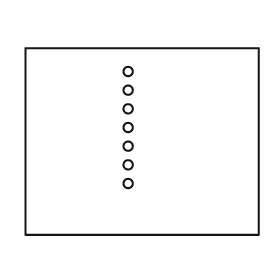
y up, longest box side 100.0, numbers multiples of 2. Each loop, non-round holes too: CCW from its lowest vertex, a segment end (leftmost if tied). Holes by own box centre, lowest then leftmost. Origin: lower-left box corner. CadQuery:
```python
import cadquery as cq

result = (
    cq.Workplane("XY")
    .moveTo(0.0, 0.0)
    .lineTo(100.0, 0.0)
    .lineTo(100.0, 80.0)
    .lineTo(0.0, 80.0)
    .close()
    .moveTo(44.0, 22.0)
    .circle(2.0)
    .moveTo(44.0, 30.0)
    .circle(2.0)
    .moveTo(44.0, 38.0)
    .circle(2.0)
    .moveTo(44.0, 46.0)
    .circle(2.0)
    .moveTo(44.0, 54.0)
    .circle(2.0)
    .moveTo(44.0, 62.0)
    .circle(2.0)
    .moveTo(44.0, 70.0)
    .circle(2.0)
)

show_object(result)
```